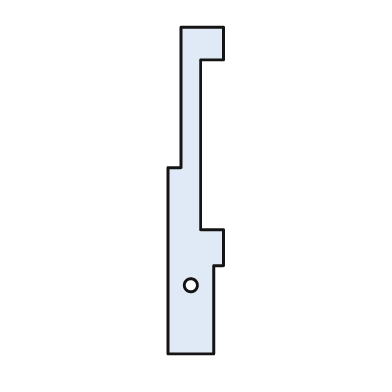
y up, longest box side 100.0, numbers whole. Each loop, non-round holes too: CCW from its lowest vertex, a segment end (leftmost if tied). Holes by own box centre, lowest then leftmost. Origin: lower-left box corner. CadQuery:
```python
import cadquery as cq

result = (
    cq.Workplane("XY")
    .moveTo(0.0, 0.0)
    .lineTo(14.0, 0.0)
    .lineTo(14.0, 27.0)
    .lineTo(17.0, 27.0)
    .lineTo(17.0, 38.0)
    .lineTo(10.0, 38.0)
    .lineTo(10.0, 90.0)
    .lineTo(17.0, 90.0)
    .lineTo(17.0, 100.0)
    .lineTo(4.0, 100.0)
    .lineTo(4.0, 57.0)
    .lineTo(0.0, 57.0)
    .close()
    .moveTo(7.0, 21.0)
    .circle(2.0)
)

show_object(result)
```